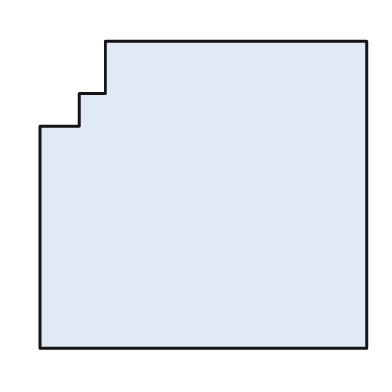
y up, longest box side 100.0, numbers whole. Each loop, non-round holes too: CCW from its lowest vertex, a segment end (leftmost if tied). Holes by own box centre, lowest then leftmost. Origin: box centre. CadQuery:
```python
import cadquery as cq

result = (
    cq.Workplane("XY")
    .moveTo(-50.0, -47.0)
    .lineTo(50.0, -47.0)
    .lineTo(50.0, 47.0)
    .lineTo(-30.0, 47.0)
    .lineTo(-30.0, 31.0)
    .lineTo(-38.0, 31.0)
    .lineTo(-38.0, 21.0)
    .lineTo(-50.0, 21.0)
    .close()
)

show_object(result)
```